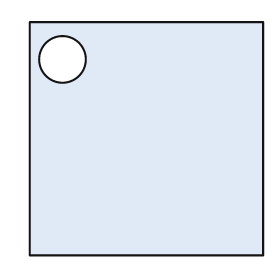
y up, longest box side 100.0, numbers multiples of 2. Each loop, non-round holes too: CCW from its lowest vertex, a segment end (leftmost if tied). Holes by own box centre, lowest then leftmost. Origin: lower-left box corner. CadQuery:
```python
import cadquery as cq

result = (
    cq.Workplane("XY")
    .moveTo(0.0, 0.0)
    .lineTo(100.0, 0.0)
    .lineTo(100.0, 100.0)
    .lineTo(0.0, 100.0)
    .close()
    .moveTo(14.0, 84.0)
    .circle(10.0)
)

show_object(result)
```